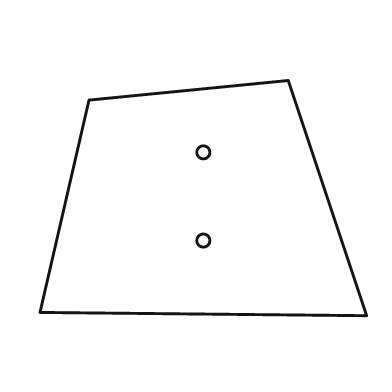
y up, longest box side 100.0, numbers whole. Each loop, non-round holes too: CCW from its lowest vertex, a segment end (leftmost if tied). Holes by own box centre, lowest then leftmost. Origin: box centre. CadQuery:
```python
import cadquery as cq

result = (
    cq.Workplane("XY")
    .moveTo(50.0, -36.0)
    .lineTo(26.0, 36.0)
    .lineTo(-35.0, 30.0)
    .lineTo(-50.0, -35.0)
    .close()
    .moveTo(0.0, -13.0)
    .circle(2.0)
    .moveTo(0.0, 14.0)
    .circle(2.0)
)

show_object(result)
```